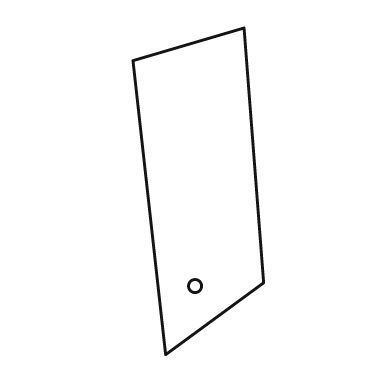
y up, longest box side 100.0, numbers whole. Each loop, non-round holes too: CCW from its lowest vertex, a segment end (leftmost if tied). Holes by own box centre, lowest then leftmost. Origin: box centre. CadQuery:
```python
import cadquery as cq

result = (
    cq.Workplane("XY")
    .moveTo(-10.0, -50.0)
    .lineTo(20.0, -28.0)
    .lineTo(14.0, 50.0)
    .lineTo(-20.0, 40.0)
    .close()
    .moveTo(-1.0, -29.0)
    .circle(2.0)
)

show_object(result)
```